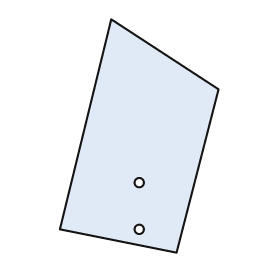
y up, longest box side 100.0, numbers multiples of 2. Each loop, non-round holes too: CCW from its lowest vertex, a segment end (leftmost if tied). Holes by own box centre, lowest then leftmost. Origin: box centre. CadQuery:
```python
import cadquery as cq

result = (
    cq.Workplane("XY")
    .moveTo(16.0, -50.0)
    .lineTo(34.0, 20.0)
    .lineTo(-12.0, 50.0)
    .lineTo(-34.0, -40.0)
    .close()
    .moveTo(0.0, -40.0)
    .circle(2.0)
    .moveTo(0.0, -20.0)
    .circle(2.0)
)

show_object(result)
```